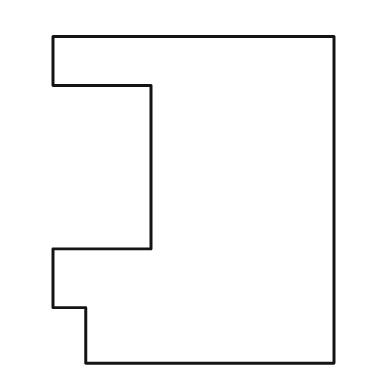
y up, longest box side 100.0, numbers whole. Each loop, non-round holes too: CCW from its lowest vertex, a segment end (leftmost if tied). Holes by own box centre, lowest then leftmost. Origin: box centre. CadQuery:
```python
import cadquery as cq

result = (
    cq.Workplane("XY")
    .moveTo(-33.0, -50.0)
    .lineTo(43.0, -50.0)
    .lineTo(43.0, 50.0)
    .lineTo(-43.0, 50.0)
    .lineTo(-43.0, 35.0)
    .lineTo(-13.0, 35.0)
    .lineTo(-13.0, -15.0)
    .lineTo(-43.0, -15.0)
    .lineTo(-43.0, -33.0)
    .lineTo(-33.0, -33.0)
    .close()
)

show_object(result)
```